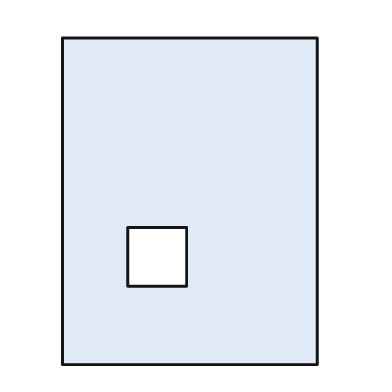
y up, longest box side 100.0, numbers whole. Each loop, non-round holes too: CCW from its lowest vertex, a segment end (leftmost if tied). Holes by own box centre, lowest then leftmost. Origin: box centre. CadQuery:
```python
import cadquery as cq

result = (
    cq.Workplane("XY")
    .moveTo(-39.0, -50.0)
    .lineTo(39.0, -50.0)
    .lineTo(39.0, 50.0)
    .lineTo(-39.0, 50.0)
    .close()
    .moveTo(-19.0, -26.0)
    .lineTo(-1.0, -26.0)
    .lineTo(-1.0, -8.0)
    .lineTo(-19.0, -8.0)
    .close()
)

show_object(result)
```